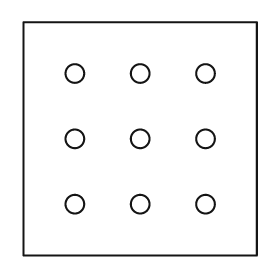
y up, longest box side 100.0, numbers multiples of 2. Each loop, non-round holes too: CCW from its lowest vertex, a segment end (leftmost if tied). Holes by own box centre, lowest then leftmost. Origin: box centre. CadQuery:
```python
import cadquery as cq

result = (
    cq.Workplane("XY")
    .moveTo(-50.0, -50.0)
    .lineTo(50.0, -50.0)
    .lineTo(50.0, 50.0)
    .lineTo(-50.0, 50.0)
    .close()
    .moveTo(-28.0, -28.0)
    .circle(4.0)
    .moveTo(0.0, -28.0)
    .circle(4.0)
    .moveTo(28.0, -28.0)
    .circle(4.0)
    .moveTo(-28.0, 0.0)
    .circle(4.0)
    .moveTo(0.0, 0.0)
    .circle(4.0)
    .moveTo(28.0, 0.0)
    .circle(4.0)
    .moveTo(-28.0, 28.0)
    .circle(4.0)
    .moveTo(0.0, 28.0)
    .circle(4.0)
    .moveTo(28.0, 28.0)
    .circle(4.0)
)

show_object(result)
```